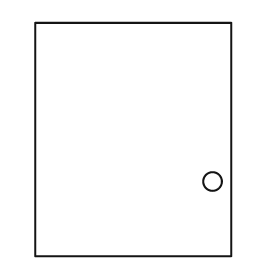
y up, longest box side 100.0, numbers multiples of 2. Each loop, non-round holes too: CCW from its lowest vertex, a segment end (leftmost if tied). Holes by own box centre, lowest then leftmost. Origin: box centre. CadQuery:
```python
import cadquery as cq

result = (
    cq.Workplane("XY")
    .moveTo(-42.0, -50.0)
    .lineTo(42.0, -50.0)
    .lineTo(42.0, 50.0)
    .lineTo(-42.0, 50.0)
    .close()
    .moveTo(34.0, -18.0)
    .circle(4.0)
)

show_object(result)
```